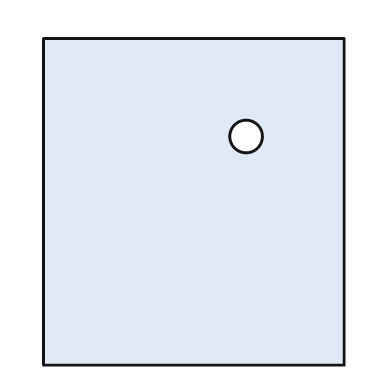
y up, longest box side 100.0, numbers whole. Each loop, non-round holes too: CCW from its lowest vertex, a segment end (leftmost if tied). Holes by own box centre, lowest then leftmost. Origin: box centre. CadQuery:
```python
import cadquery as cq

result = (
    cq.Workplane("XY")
    .moveTo(-46.0, -50.0)
    .lineTo(46.0, -50.0)
    .lineTo(46.0, 50.0)
    .lineTo(-46.0, 50.0)
    .close()
    .moveTo(16.0, 20.0)
    .circle(5.0)
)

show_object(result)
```